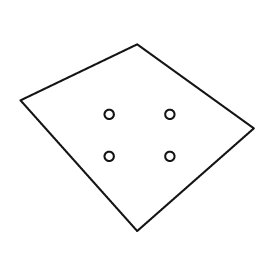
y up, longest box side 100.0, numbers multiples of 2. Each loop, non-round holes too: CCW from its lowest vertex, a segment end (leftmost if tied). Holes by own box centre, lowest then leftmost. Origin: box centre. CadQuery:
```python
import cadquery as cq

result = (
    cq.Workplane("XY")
    .moveTo(0.0, -40.0)
    .lineTo(50.0, 4.0)
    .lineTo(0.0, 40.0)
    .lineTo(-50.0, 16.0)
    .close()
    .moveTo(-12.0, -8.0)
    .circle(2.0)
    .moveTo(14.0, -8.0)
    .circle(2.0)
    .moveTo(-12.0, 10.0)
    .circle(2.0)
    .moveTo(14.0, 10.0)
    .circle(2.0)
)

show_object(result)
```